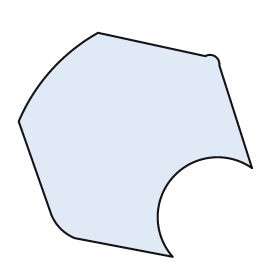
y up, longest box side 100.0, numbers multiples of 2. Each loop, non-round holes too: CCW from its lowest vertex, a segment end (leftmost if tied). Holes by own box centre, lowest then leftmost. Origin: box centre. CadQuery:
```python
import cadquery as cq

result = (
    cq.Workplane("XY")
    .moveTo(16.0, -48.0)
    .threePointArc((16.0, -14.0), (50.0, -10.0))
    .lineTo(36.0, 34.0)
    .threePointArc((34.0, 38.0), (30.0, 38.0))
    .lineTo(-16.0, 48.0)
    .threePointArc((-36.0, 32.0), (-50.0, 10.0))
    .lineTo(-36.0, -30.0)
    .threePointArc((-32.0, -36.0), (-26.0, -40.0))
    .close()
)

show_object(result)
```